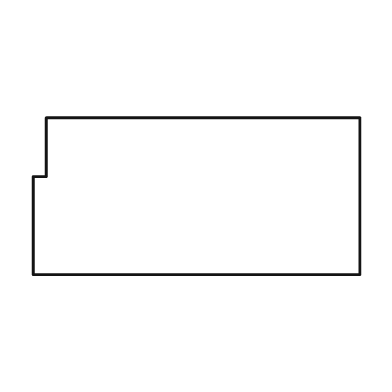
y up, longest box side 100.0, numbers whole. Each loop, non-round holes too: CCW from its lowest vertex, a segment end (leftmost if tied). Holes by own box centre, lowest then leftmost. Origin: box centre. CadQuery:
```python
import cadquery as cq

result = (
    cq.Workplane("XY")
    .moveTo(-50.0, -24.0)
    .lineTo(50.0, -24.0)
    .lineTo(50.0, 24.0)
    .lineTo(-46.0, 24.0)
    .lineTo(-46.0, 6.0)
    .lineTo(-50.0, 6.0)
    .close()
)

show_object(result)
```